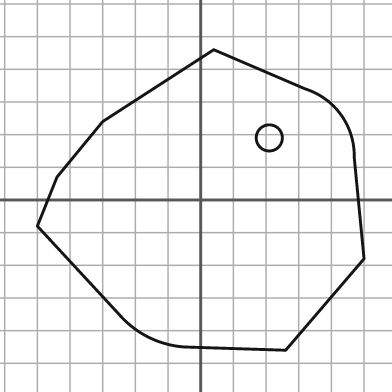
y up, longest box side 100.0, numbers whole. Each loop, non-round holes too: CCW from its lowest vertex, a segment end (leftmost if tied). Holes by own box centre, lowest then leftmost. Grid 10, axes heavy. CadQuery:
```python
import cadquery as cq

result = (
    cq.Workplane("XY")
    .moveTo(26.0, -46.0)
    .lineTo(50.0, -18.0)
    .lineTo(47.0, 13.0)
    .threePointArc((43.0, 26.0), (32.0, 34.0))
    .lineTo(4.0, 46.0)
    .lineTo(-30.0, 24.0)
    .lineTo(-44.0, 7.0)
    .lineTo(-50.0, -8.0)
    .lineTo(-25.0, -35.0)
    .threePointArc((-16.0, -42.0), (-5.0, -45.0))
    .close()
    .moveTo(21.0, 19.0)
    .circle(4.0)
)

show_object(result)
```